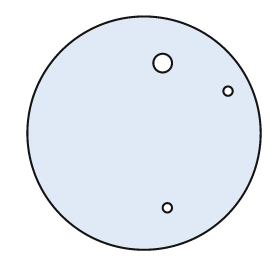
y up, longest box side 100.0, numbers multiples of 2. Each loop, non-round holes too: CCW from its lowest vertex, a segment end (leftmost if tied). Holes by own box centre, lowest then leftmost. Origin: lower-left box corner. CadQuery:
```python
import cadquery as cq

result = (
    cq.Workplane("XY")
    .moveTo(50.0, 50.0)
    .circle(50.0)
    .moveTo(60.0, 18.0)
    .circle(2.0)
    .moveTo(86.0, 68.0)
    .circle(2.0)
    .moveTo(58.0, 80.0)
    .circle(4.0)
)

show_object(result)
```